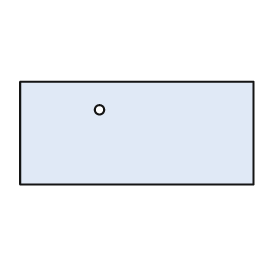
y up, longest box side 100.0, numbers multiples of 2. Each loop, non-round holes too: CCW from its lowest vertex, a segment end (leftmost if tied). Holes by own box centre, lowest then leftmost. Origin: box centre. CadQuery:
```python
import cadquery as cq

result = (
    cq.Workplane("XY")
    .moveTo(-50.0, -22.0)
    .lineTo(50.0, -22.0)
    .lineTo(50.0, 22.0)
    .lineTo(-50.0, 22.0)
    .close()
    .moveTo(-16.0, 10.0)
    .circle(2.0)
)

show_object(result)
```